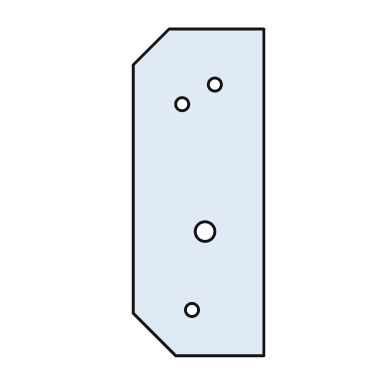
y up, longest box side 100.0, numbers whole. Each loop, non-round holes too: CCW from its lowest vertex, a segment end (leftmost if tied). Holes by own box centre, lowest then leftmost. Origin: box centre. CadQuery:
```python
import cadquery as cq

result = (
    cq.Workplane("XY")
    .moveTo(-7.0, -50.0)
    .lineTo(20.0, -50.0)
    .lineTo(20.0, 50.0)
    .lineTo(-9.0, 50.0)
    .lineTo(-20.0, 39.0)
    .lineTo(-20.0, -37.0)
    .close()
    .moveTo(-2.0, -36.0)
    .circle(2.0)
    .moveTo(2.0, -12.0)
    .circle(3.0)
    .moveTo(-5.0, 27.0)
    .circle(2.0)
    .moveTo(5.0, 33.0)
    .circle(2.0)
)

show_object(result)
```